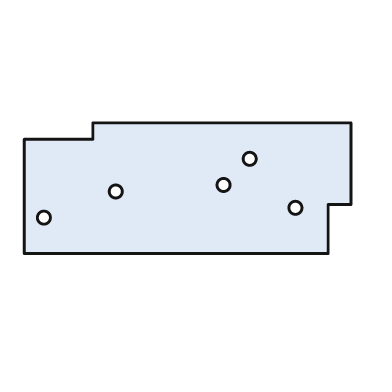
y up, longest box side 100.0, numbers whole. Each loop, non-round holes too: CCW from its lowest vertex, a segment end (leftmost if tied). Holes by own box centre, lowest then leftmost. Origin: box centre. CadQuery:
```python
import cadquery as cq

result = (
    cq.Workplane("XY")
    .moveTo(-50.0, -20.0)
    .lineTo(43.0, -20.0)
    .lineTo(43.0, -5.0)
    .lineTo(50.0, -5.0)
    .lineTo(50.0, 20.0)
    .lineTo(-29.0, 20.0)
    .lineTo(-29.0, 15.0)
    .lineTo(-50.0, 15.0)
    .close()
    .moveTo(-44.0, -9.0)
    .circle(2.0)
    .moveTo(33.0, -6.0)
    .circle(2.0)
    .moveTo(-22.0, -1.0)
    .circle(2.0)
    .moveTo(11.0, 1.0)
    .circle(2.0)
    .moveTo(19.0, 9.0)
    .circle(2.0)
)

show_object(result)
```